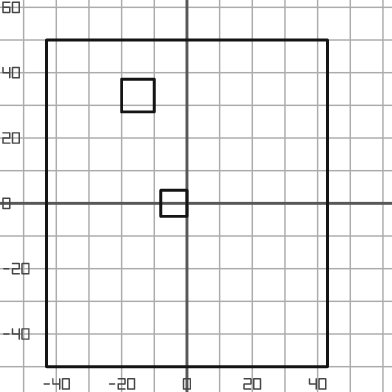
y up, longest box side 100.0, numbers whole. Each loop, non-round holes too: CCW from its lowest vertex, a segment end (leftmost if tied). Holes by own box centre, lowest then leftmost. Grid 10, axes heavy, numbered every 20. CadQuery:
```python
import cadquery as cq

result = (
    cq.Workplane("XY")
    .moveTo(-43.0, -50.0)
    .lineTo(43.0, -50.0)
    .lineTo(43.0, 50.0)
    .lineTo(-43.0, 50.0)
    .close()
    .moveTo(-8.0, -4.0)
    .lineTo(0.0, -4.0)
    .lineTo(0.0, 4.0)
    .lineTo(-8.0, 4.0)
    .close()
    .moveTo(-20.0, 28.0)
    .lineTo(-10.0, 28.0)
    .lineTo(-10.0, 38.0)
    .lineTo(-20.0, 38.0)
    .close()
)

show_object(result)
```